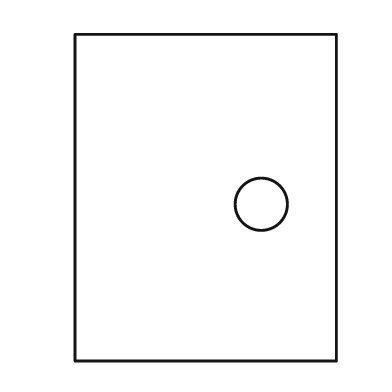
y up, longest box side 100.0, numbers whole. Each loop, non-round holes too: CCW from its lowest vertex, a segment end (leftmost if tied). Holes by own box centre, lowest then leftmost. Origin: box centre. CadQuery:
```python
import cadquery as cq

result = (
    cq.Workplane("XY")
    .moveTo(-40.0, -50.0)
    .lineTo(40.0, -50.0)
    .lineTo(40.0, 50.0)
    .lineTo(-40.0, 50.0)
    .close()
    .moveTo(17.0, -2.0)
    .circle(8.0)
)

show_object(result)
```